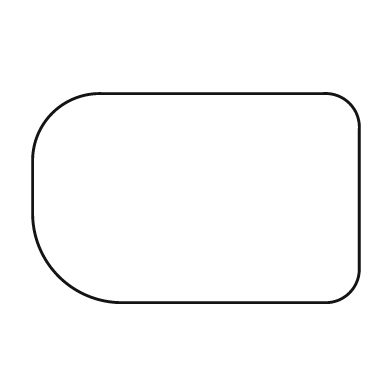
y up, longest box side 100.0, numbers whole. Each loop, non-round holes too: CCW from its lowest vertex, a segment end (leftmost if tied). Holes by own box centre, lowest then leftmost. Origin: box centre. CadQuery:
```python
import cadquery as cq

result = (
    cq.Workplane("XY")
    .moveTo(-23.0, -32.0)
    .lineTo(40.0, -32.0)
    .threePointArc((47.0, -29.0), (50.0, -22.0))
    .lineTo(50.0, 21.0)
    .threePointArc((47.0, 29.0), (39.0, 32.0))
    .lineTo(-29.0, 32.0)
    .threePointArc((-44.0, 26.0), (-50.0, 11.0))
    .lineTo(-50.0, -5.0)
    .threePointArc((-42.0, -24.0), (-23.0, -32.0))
    .close()
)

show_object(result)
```